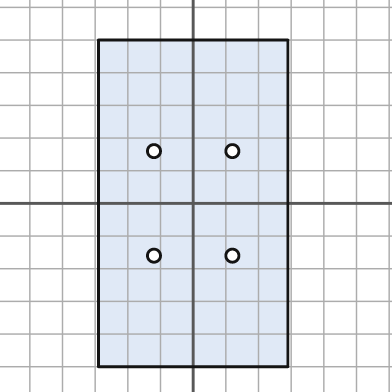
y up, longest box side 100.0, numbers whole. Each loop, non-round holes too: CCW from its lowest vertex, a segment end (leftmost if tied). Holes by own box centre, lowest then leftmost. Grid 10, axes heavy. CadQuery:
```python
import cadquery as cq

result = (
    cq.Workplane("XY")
    .moveTo(-29.0, -50.0)
    .lineTo(29.0, -50.0)
    .lineTo(29.0, 50.0)
    .lineTo(-29.0, 50.0)
    .close()
    .moveTo(-12.0, -16.0)
    .circle(2.0)
    .moveTo(12.0, -16.0)
    .circle(2.0)
    .moveTo(-12.0, 16.0)
    .circle(2.0)
    .moveTo(12.0, 16.0)
    .circle(2.0)
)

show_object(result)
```